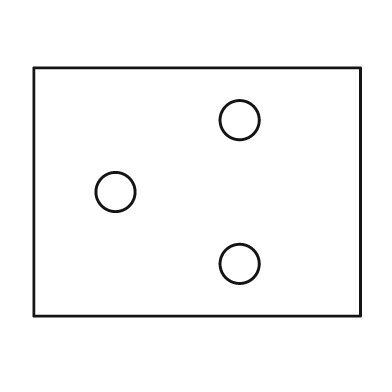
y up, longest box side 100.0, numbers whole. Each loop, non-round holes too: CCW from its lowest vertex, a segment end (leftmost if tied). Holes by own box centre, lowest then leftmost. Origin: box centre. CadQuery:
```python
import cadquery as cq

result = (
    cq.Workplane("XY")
    .moveTo(-50.0, -38.0)
    .lineTo(50.0, -38.0)
    .lineTo(50.0, 38.0)
    .lineTo(-50.0, 38.0)
    .close()
    .moveTo(13.0, -22.0)
    .circle(6.0)
    .moveTo(-25.0, 0.0)
    .circle(6.0)
    .moveTo(13.0, 22.0)
    .circle(6.0)
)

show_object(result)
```